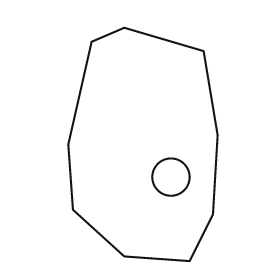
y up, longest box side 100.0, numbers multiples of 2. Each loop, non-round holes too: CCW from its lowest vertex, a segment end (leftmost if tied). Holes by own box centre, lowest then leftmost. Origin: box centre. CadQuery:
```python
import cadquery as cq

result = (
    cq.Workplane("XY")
    .moveTo(20.0, -50.0)
    .lineTo(30.0, -30.0)
    .lineTo(32.0, 4.0)
    .lineTo(26.0, 40.0)
    .lineTo(-8.0, 50.0)
    .lineTo(-22.0, 44.0)
    .lineTo(-32.0, 0.0)
    .lineTo(-30.0, -28.0)
    .lineTo(-8.0, -48.0)
    .close()
    .moveTo(12.0, -14.0)
    .circle(8.0)
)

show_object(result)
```